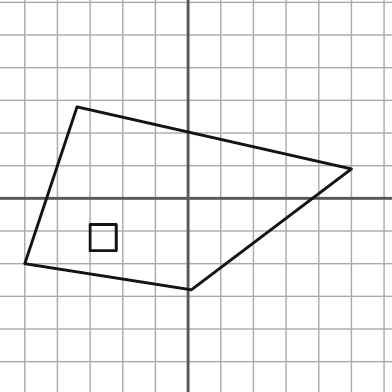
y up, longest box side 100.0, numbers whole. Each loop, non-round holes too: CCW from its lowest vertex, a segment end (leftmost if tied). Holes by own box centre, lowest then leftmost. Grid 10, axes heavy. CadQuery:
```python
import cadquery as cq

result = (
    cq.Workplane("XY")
    .moveTo(1.0, -28.0)
    .lineTo(50.0, 9.0)
    .lineTo(-34.0, 28.0)
    .lineTo(-50.0, -20.0)
    .close()
    .moveTo(-30.0, -16.0)
    .lineTo(-22.0, -16.0)
    .lineTo(-22.0, -8.0)
    .lineTo(-30.0, -8.0)
    .close()
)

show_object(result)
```